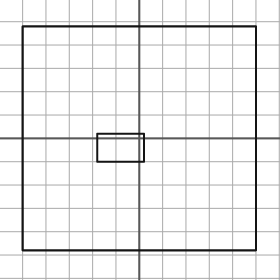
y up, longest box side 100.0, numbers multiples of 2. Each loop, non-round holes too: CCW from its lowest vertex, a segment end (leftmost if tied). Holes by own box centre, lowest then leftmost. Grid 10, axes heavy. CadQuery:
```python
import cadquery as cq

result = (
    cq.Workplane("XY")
    .moveTo(-50.0, -48.0)
    .lineTo(50.0, -48.0)
    .lineTo(50.0, 48.0)
    .lineTo(-50.0, 48.0)
    .close()
    .moveTo(-18.0, -10.0)
    .lineTo(2.0, -10.0)
    .lineTo(2.0, 2.0)
    .lineTo(-18.0, 2.0)
    .close()
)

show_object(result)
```